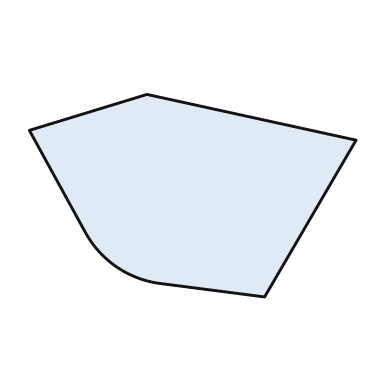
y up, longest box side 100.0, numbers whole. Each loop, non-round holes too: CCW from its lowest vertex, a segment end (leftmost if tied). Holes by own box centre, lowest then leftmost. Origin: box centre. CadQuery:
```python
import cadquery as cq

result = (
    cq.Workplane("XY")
    .moveTo(22.0, -31.0)
    .lineTo(50.0, 17.0)
    .lineTo(-14.0, 31.0)
    .lineTo(-50.0, 20.0)
    .lineTo(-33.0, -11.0)
    .threePointArc((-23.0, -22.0), (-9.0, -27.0))
    .close()
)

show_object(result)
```